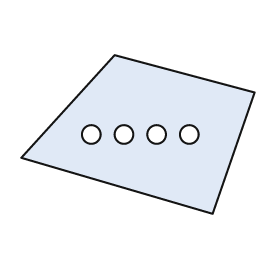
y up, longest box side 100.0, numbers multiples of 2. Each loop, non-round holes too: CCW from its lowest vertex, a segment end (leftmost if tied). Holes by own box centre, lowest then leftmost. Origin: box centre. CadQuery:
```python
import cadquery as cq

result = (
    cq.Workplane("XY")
    .moveTo(32.0, -34.0)
    .lineTo(50.0, 18.0)
    .lineTo(-10.0, 34.0)
    .lineTo(-50.0, -10.0)
    .close()
    .moveTo(-20.0, 0.0)
    .circle(4.0)
    .moveTo(-6.0, 0.0)
    .circle(4.0)
    .moveTo(8.0, 0.0)
    .circle(4.0)
    .moveTo(22.0, 0.0)
    .circle(4.0)
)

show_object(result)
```